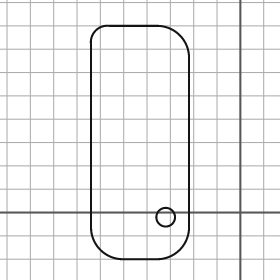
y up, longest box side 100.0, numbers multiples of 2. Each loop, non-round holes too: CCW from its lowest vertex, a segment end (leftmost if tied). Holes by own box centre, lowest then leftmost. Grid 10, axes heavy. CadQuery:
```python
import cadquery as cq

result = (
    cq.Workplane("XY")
    .moveTo(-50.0, -20.0)
    .lineTo(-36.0, -20.0)
    .threePointArc((-26.0, -16.0), (-22.0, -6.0))
    .lineTo(-22.0, 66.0)
    .threePointArc((-26.0, 76.0), (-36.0, 80.0))
    .lineTo(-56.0, 80.0)
    .threePointArc((-62.0, 78.0), (-64.0, 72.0))
    .lineTo(-64.0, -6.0)
    .threePointArc((-60.0, -16.0), (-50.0, -20.0))
    .close()
    .moveTo(-32.0, -2.0)
    .circle(4.0)
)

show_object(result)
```